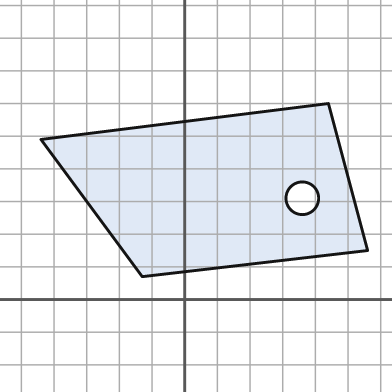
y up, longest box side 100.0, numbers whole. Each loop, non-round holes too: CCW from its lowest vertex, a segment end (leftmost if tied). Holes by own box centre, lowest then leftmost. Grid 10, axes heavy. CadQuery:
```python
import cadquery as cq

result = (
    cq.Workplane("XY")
    .moveTo(-13.0, 7.0)
    .lineTo(56.0, 15.0)
    .lineTo(44.0, 60.0)
    .lineTo(-44.0, 49.0)
    .close()
    .moveTo(36.0, 31.0)
    .circle(5.0)
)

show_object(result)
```